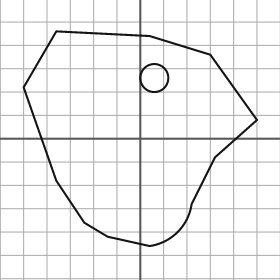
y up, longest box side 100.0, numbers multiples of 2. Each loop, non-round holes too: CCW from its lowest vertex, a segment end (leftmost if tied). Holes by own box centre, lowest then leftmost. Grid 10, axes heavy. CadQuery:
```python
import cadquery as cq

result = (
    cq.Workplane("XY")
    .moveTo(4.0, -46.0)
    .threePointArc((16.0, -40.0), (22.0, -28.0))
    .lineTo(32.0, -8.0)
    .lineTo(50.0, 8.0)
    .lineTo(30.0, 36.0)
    .lineTo(4.0, 44.0)
    .lineTo(-36.0, 46.0)
    .lineTo(-50.0, 22.0)
    .lineTo(-36.0, -18.0)
    .lineTo(-24.0, -36.0)
    .lineTo(-14.0, -42.0)
    .close()
    .moveTo(6.0, 26.0)
    .circle(6.0)
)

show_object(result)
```